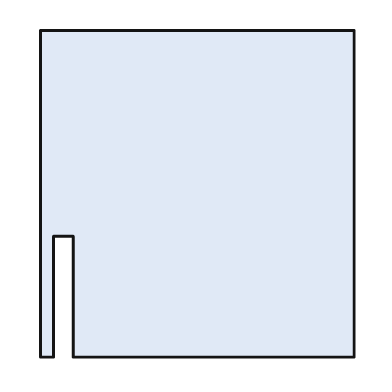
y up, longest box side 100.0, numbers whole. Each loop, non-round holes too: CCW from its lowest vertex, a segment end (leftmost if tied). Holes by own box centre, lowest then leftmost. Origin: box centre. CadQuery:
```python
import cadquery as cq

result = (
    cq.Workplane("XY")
    .moveTo(-48.0, -50.0)
    .lineTo(-44.0, -50.0)
    .lineTo(-44.0, -13.0)
    .lineTo(-38.0, -13.0)
    .lineTo(-38.0, -50.0)
    .lineTo(48.0, -50.0)
    .lineTo(48.0, 50.0)
    .lineTo(-48.0, 50.0)
    .close()
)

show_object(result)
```